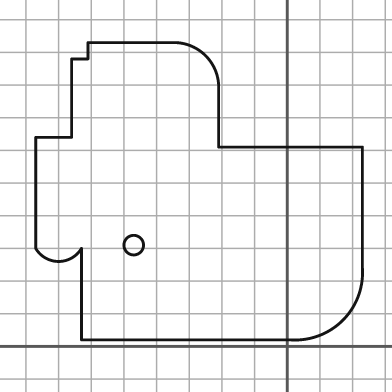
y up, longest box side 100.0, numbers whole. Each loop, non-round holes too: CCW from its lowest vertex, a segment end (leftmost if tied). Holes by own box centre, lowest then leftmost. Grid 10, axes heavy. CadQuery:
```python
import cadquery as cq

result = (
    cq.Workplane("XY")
    .moveTo(-63.0, 2.0)
    .lineTo(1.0, 2.0)
    .threePointArc((17.0, 8.0), (23.0, 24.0))
    .lineTo(23.0, 61.0)
    .lineTo(-21.0, 61.0)
    .lineTo(-21.0, 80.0)
    .threePointArc((-25.0, 89.0), (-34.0, 93.0))
    .lineTo(-61.0, 93.0)
    .lineTo(-61.0, 88.0)
    .lineTo(-66.0, 88.0)
    .lineTo(-66.0, 64.0)
    .lineTo(-77.0, 64.0)
    .lineTo(-77.0, 30.0)
    .threePointArc((-70.0, 26.0), (-63.0, 30.0))
    .close()
    .moveTo(-47.0, 31.0)
    .circle(3.0)
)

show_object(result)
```